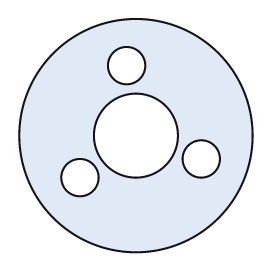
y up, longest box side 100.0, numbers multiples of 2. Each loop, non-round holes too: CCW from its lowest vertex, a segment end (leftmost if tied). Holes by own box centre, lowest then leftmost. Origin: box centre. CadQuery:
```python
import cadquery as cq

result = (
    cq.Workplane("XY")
    .moveTo(0.0, 0.0)
    .circle(50.0)
    .moveTo(-24.0, -18.0)
    .circle(8.0)
    .moveTo(28.0, -10.0)
    .circle(8.0)
    .moveTo(0.0, 0.0)
    .circle(18.0)
    .moveTo(-4.0, 30.0)
    .circle(8.0)
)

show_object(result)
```